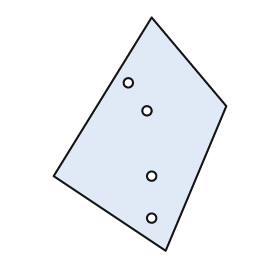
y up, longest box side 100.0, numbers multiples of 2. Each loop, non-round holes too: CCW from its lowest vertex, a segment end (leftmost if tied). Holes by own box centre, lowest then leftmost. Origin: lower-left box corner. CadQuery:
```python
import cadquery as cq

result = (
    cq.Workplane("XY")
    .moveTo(48.0, 0.0)
    .lineTo(74.0, 62.0)
    .lineTo(42.0, 100.0)
    .lineTo(0.0, 32.0)
    .close()
    .moveTo(42.0, 14.0)
    .circle(2.0)
    .moveTo(42.0, 32.0)
    .circle(2.0)
    .moveTo(40.0, 60.0)
    .circle(2.0)
    .moveTo(32.0, 72.0)
    .circle(2.0)
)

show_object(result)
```